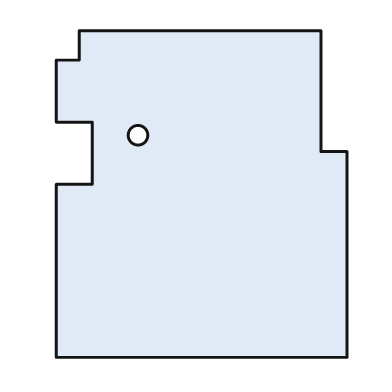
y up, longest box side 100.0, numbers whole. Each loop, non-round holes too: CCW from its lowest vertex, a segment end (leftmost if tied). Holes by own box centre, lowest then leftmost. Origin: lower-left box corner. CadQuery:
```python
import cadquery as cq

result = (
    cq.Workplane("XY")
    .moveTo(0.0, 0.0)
    .lineTo(89.0, 0.0)
    .lineTo(89.0, 63.0)
    .lineTo(81.0, 63.0)
    .lineTo(81.0, 100.0)
    .lineTo(7.0, 100.0)
    .lineTo(7.0, 91.0)
    .lineTo(0.0, 91.0)
    .lineTo(0.0, 72.0)
    .lineTo(11.0, 72.0)
    .lineTo(11.0, 53.0)
    .lineTo(0.0, 53.0)
    .close()
    .moveTo(25.0, 68.0)
    .circle(3.0)
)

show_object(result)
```